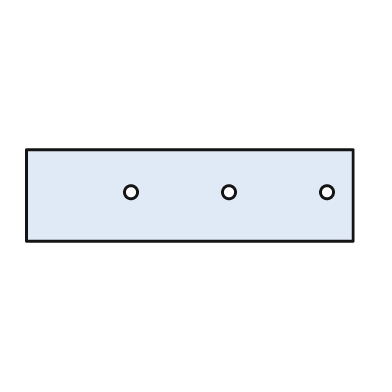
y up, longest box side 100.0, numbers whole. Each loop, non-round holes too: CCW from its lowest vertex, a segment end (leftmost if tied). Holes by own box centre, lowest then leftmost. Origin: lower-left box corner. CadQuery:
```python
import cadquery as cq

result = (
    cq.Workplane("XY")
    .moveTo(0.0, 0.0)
    .lineTo(100.0, 0.0)
    .lineTo(100.0, 28.0)
    .lineTo(0.0, 28.0)
    .close()
    .moveTo(32.0, 15.0)
    .circle(2.0)
    .moveTo(62.0, 15.0)
    .circle(2.0)
    .moveTo(92.0, 15.0)
    .circle(2.0)
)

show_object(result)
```